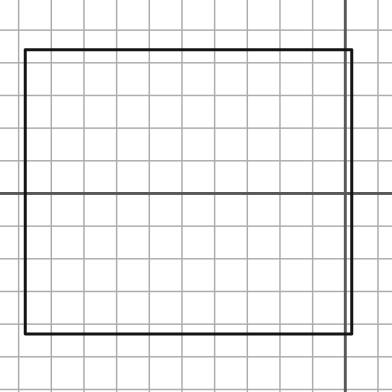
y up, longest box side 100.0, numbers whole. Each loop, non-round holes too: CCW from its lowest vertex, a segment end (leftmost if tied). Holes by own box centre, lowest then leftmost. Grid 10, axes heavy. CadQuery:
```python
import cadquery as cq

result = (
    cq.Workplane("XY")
    .moveTo(-98.0, -43.0)
    .lineTo(2.0, -43.0)
    .lineTo(2.0, 44.0)
    .lineTo(-98.0, 44.0)
    .close()
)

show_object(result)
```